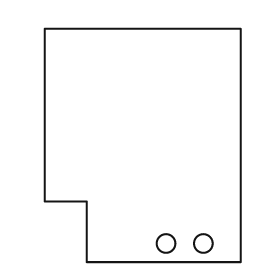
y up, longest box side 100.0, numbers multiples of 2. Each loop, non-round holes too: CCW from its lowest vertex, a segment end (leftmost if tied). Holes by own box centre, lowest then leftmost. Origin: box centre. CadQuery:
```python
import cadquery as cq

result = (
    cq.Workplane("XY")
    .moveTo(-24.0, -50.0)
    .lineTo(42.0, -50.0)
    .lineTo(42.0, 50.0)
    .lineTo(-42.0, 50.0)
    .lineTo(-42.0, -24.0)
    .lineTo(-24.0, -24.0)
    .close()
    .moveTo(10.0, -42.0)
    .circle(4.0)
    .moveTo(26.0, -42.0)
    .circle(4.0)
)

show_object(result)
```